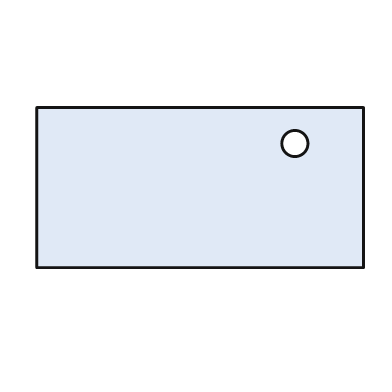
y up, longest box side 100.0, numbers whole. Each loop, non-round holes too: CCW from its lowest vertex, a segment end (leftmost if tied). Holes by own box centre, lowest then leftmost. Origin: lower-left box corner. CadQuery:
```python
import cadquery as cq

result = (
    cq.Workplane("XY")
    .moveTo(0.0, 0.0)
    .lineTo(100.0, 0.0)
    .lineTo(100.0, 49.0)
    .lineTo(0.0, 49.0)
    .close()
    .moveTo(79.0, 38.0)
    .circle(4.0)
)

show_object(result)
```